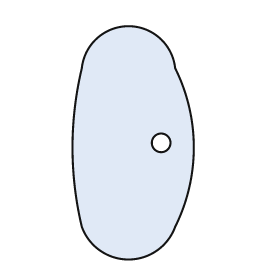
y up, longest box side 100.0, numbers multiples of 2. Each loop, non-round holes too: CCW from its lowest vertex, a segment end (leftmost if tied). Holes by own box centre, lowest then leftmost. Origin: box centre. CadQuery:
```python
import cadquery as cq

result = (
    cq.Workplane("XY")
    .moveTo(-22.0, -36.0)
    .threePointArc((-2.0, -50.0), (18.0, -36.0))
    .threePointArc((26.0, -2.0), (18.0, 32.0))
    .threePointArc((-2.0, 50.0), (-22.0, 32.0))
    .threePointArc((-26.0, -2.0), (-22.0, -36.0))
    .close()
    .moveTo(12.0, 0.0)
    .circle(4.0)
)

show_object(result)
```